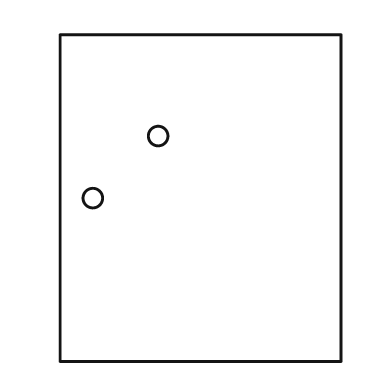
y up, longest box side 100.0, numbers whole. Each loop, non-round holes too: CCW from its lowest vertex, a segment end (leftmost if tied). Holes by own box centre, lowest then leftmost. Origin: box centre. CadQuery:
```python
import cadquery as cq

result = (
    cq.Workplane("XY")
    .moveTo(-43.0, -50.0)
    .lineTo(43.0, -50.0)
    .lineTo(43.0, 50.0)
    .lineTo(-43.0, 50.0)
    .close()
    .moveTo(-33.0, 0.0)
    .circle(3.0)
    .moveTo(-13.0, 19.0)
    .circle(3.0)
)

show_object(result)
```